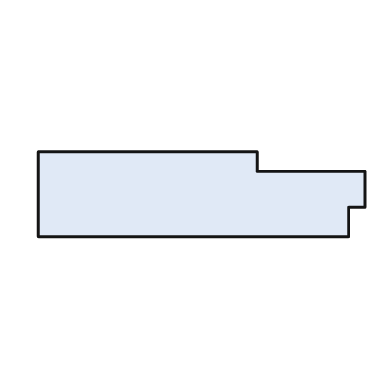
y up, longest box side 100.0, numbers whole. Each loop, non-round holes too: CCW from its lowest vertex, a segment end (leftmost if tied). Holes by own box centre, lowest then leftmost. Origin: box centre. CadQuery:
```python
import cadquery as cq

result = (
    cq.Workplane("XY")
    .moveTo(-50.0, -13.0)
    .lineTo(45.0, -13.0)
    .lineTo(45.0, -4.0)
    .lineTo(50.0, -4.0)
    .lineTo(50.0, 7.0)
    .lineTo(17.0, 7.0)
    .lineTo(17.0, 13.0)
    .lineTo(-50.0, 13.0)
    .close()
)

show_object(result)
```